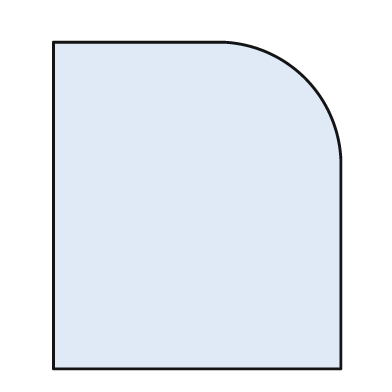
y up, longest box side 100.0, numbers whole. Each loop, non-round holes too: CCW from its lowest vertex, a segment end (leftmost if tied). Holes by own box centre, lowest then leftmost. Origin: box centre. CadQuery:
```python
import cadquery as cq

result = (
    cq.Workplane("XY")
    .moveTo(-44.0, -50.0)
    .lineTo(44.0, -50.0)
    .lineTo(44.0, 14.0)
    .threePointArc((33.0, 39.0), (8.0, 50.0))
    .lineTo(-44.0, 50.0)
    .close()
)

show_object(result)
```